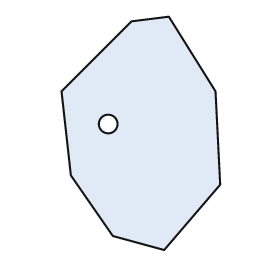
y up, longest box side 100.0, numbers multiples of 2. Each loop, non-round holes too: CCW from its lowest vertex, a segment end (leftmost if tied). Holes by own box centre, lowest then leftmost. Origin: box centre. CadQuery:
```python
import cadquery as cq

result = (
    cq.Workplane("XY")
    .moveTo(10.0, -50.0)
    .lineTo(34.0, -22.0)
    .lineTo(32.0, 18.0)
    .lineTo(12.0, 50.0)
    .lineTo(-4.0, 48.0)
    .lineTo(-34.0, 18.0)
    .lineTo(-30.0, -18.0)
    .lineTo(-12.0, -44.0)
    .close()
    .moveTo(-14.0, 4.0)
    .circle(4.0)
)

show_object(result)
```